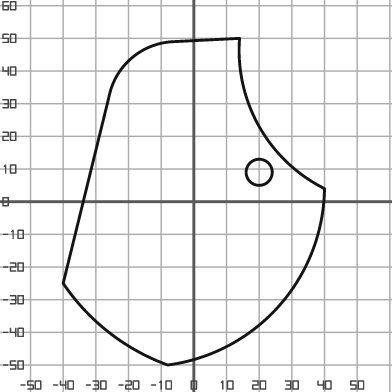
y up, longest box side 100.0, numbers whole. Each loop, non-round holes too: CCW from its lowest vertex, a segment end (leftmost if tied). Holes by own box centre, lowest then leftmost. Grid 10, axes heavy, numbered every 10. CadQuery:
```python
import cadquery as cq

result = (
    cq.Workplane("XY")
    .moveTo(-8.0, -50.0)
    .threePointArc((26.0, -32.0), (40.0, 4.0))
    .threePointArc((20.0, 23.0), (14.0, 50.0))
    .lineTo(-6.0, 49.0)
    .threePointArc((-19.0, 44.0), (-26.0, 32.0))
    .lineTo(-40.0, -25.0)
    .threePointArc((-26.0, -40.0), (-8.0, -50.0))
    .close()
    .moveTo(20.0, 9.0)
    .circle(4.0)
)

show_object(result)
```